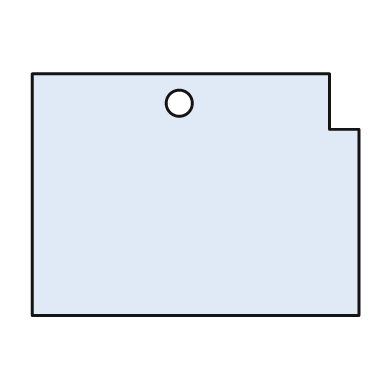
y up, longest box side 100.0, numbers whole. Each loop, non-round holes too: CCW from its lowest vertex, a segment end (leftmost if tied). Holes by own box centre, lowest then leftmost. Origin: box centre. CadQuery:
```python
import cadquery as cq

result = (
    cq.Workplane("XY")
    .moveTo(-50.0, -37.0)
    .lineTo(50.0, -37.0)
    .lineTo(50.0, 20.0)
    .lineTo(41.0, 20.0)
    .lineTo(41.0, 37.0)
    .lineTo(-50.0, 37.0)
    .close()
    .moveTo(-5.0, 28.0)
    .circle(4.0)
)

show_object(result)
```